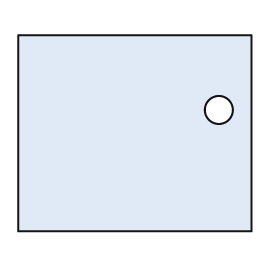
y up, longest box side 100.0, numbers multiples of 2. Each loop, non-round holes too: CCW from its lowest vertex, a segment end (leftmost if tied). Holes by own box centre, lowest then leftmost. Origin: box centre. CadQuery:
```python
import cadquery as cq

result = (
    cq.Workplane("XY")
    .moveTo(-50.0, -42.0)
    .lineTo(50.0, -42.0)
    .lineTo(50.0, 42.0)
    .lineTo(-50.0, 42.0)
    .close()
    .moveTo(36.0, 10.0)
    .circle(6.0)
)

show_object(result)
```